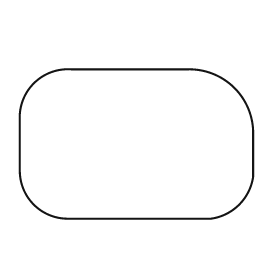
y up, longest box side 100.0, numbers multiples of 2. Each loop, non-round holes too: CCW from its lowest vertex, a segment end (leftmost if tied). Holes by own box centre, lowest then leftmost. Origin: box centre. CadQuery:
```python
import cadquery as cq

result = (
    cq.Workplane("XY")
    .moveTo(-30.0, -32.0)
    .lineTo(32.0, -32.0)
    .threePointArc((44.0, -26.0), (50.0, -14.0))
    .lineTo(50.0, 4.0)
    .threePointArc((42.0, 24.0), (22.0, 32.0))
    .lineTo(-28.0, 32.0)
    .threePointArc((-44.0, 26.0), (-50.0, 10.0))
    .lineTo(-50.0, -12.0)
    .threePointArc((-44.0, -26.0), (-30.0, -32.0))
    .close()
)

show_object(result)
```